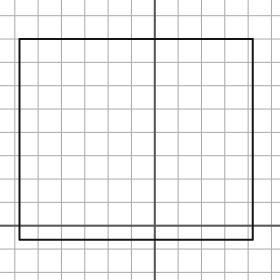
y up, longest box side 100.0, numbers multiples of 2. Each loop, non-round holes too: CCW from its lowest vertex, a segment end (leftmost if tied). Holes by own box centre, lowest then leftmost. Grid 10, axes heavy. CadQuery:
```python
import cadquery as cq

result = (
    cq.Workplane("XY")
    .moveTo(-58.0, -6.0)
    .lineTo(42.0, -6.0)
    .lineTo(42.0, 80.0)
    .lineTo(-58.0, 80.0)
    .close()
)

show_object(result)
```